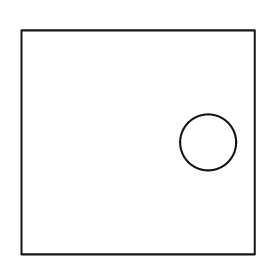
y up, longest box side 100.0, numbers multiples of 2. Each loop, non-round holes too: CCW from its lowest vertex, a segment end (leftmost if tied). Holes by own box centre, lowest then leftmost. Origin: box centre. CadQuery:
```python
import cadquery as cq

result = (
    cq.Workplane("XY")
    .moveTo(-50.0, -48.0)
    .lineTo(50.0, -48.0)
    .lineTo(50.0, 48.0)
    .lineTo(-50.0, 48.0)
    .close()
    .moveTo(30.0, 0.0)
    .circle(12.0)
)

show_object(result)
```